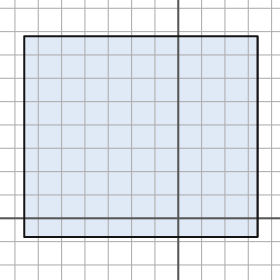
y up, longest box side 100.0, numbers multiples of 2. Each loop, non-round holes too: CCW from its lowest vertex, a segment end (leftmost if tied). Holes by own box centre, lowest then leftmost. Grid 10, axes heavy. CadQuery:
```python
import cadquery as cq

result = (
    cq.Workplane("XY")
    .moveTo(-66.0, -8.0)
    .lineTo(34.0, -8.0)
    .lineTo(34.0, 78.0)
    .lineTo(-66.0, 78.0)
    .close()
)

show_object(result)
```